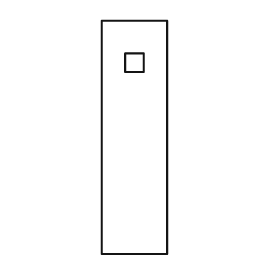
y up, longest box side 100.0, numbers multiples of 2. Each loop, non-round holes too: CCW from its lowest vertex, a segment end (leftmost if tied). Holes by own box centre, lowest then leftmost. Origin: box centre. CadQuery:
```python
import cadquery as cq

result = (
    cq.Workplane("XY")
    .moveTo(-14.0, -50.0)
    .lineTo(14.0, -50.0)
    .lineTo(14.0, 50.0)
    .lineTo(-14.0, 50.0)
    .close()
    .moveTo(-4.0, 28.0)
    .lineTo(4.0, 28.0)
    .lineTo(4.0, 36.0)
    .lineTo(-4.0, 36.0)
    .close()
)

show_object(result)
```